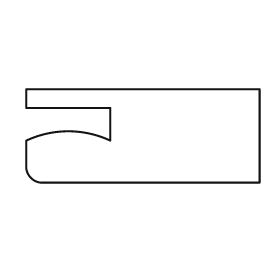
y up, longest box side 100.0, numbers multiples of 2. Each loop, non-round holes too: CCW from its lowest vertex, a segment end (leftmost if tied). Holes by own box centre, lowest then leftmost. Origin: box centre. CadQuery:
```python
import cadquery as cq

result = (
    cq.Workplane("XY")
    .moveTo(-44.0, -20.0)
    .lineTo(50.0, -20.0)
    .lineTo(50.0, 20.0)
    .lineTo(-50.0, 20.0)
    .lineTo(-50.0, 12.0)
    .lineTo(-14.0, 12.0)
    .lineTo(-14.0, -2.0)
    .threePointArc((-32.0, 2.0), (-50.0, -2.0))
    .lineTo(-50.0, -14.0)
    .threePointArc((-48.0, -18.0), (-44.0, -20.0))
    .close()
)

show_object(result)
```